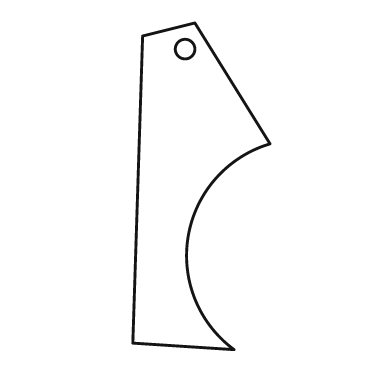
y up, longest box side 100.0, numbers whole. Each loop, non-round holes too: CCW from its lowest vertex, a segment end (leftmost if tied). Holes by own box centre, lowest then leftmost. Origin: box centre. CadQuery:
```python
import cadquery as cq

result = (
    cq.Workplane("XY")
    .moveTo(10.0, -50.0)
    .threePointArc((-4.0, -15.0), (21.0, 13.0))
    .lineTo(-2.0, 50.0)
    .lineTo(-18.0, 46.0)
    .lineTo(-21.0, -48.0)
    .close()
    .moveTo(-5.0, 42.0)
    .circle(3.0)
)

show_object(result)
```